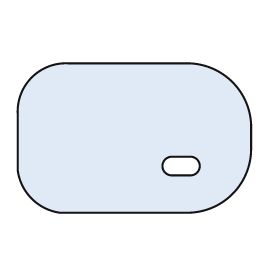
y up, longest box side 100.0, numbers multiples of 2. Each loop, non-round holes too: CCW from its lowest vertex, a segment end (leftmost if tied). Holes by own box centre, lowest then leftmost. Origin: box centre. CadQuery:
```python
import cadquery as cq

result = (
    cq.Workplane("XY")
    .moveTo(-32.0, -32.0)
    .lineTo(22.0, -32.0)
    .threePointArc((42.0, -24.0), (50.0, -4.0))
    .lineTo(50.0, 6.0)
    .threePointArc((42.0, 24.0), (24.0, 32.0))
    .lineTo(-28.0, 32.0)
    .threePointArc((-44.0, 26.0), (-50.0, 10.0))
    .lineTo(-50.0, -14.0)
    .threePointArc((-44.0, -26.0), (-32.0, -32.0))
    .close()
    .moveTo(16.0, -16.0)
    .lineTo(24.0, -16.0)
    .threePointArc((28.0, -12.0), (24.0, -8.0))
    .lineTo(16.0, -8.0)
    .threePointArc((12.0, -12.0), (16.0, -16.0))
    .close()
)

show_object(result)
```